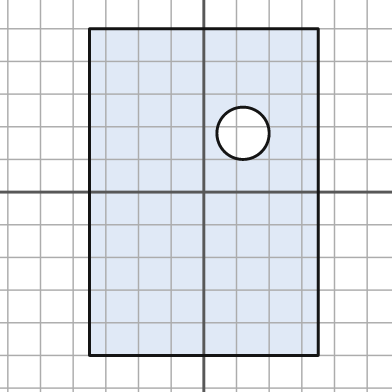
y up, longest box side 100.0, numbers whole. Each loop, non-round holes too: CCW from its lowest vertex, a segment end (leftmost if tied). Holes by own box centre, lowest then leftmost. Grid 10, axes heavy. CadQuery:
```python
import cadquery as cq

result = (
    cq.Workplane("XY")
    .moveTo(-35.0, -50.0)
    .lineTo(35.0, -50.0)
    .lineTo(35.0, 50.0)
    .lineTo(-35.0, 50.0)
    .close()
    .moveTo(12.0, 18.0)
    .circle(8.0)
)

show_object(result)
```